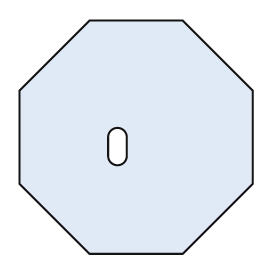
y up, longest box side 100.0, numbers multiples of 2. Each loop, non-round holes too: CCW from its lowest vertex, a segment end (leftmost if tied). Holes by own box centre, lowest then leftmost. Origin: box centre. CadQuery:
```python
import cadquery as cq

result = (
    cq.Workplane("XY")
    .moveTo(-20.0, -50.0)
    .lineTo(20.0, -50.0)
    .lineTo(50.0, -20.0)
    .lineTo(50.0, 20.0)
    .lineTo(20.0, 50.0)
    .lineTo(-20.0, 50.0)
    .lineTo(-50.0, 20.0)
    .lineTo(-50.0, -20.0)
    .close()
    .moveTo(-12.0, -8.0)
    .threePointArc((-8.0, -12.0), (-4.0, -8.0))
    .lineTo(-4.0, 0.0)
    .threePointArc((-8.0, 4.0), (-12.0, 0.0))
    .close()
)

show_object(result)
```